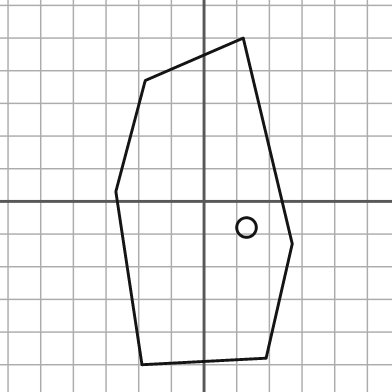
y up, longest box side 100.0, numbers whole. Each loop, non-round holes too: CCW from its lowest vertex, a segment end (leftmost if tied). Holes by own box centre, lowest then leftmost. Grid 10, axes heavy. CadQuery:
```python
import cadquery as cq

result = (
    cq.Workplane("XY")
    .moveTo(-19.0, -50.0)
    .lineTo(19.0, -48.0)
    .lineTo(27.0, -13.0)
    .lineTo(12.0, 50.0)
    .lineTo(-18.0, 37.0)
    .lineTo(-27.0, 3.0)
    .close()
    .moveTo(13.0, -8.0)
    .circle(3.0)
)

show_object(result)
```